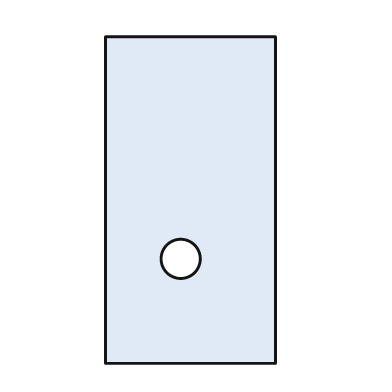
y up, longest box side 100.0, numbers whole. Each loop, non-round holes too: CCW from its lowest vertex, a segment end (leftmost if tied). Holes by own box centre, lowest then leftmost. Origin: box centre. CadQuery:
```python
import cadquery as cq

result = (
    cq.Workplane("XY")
    .moveTo(-26.0, -50.0)
    .lineTo(26.0, -50.0)
    .lineTo(26.0, 50.0)
    .lineTo(-26.0, 50.0)
    .close()
    .moveTo(-3.0, -18.0)
    .circle(6.0)
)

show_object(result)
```